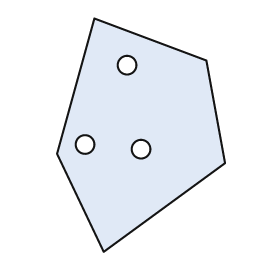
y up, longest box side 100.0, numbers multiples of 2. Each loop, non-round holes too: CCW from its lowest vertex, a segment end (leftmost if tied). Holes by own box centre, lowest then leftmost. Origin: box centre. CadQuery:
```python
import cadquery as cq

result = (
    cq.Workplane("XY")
    .moveTo(-16.0, -50.0)
    .lineTo(36.0, -12.0)
    .lineTo(28.0, 32.0)
    .lineTo(-20.0, 50.0)
    .lineTo(-36.0, -8.0)
    .close()
    .moveTo(0.0, -6.0)
    .circle(4.0)
    .moveTo(-24.0, -4.0)
    .circle(4.0)
    .moveTo(-6.0, 30.0)
    .circle(4.0)
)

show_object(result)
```